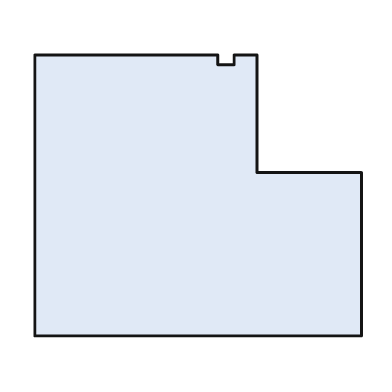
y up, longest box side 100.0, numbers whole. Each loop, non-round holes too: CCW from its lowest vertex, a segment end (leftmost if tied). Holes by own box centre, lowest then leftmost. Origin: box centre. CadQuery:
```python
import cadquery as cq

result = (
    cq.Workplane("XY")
    .moveTo(-50.0, -43.0)
    .lineTo(50.0, -43.0)
    .lineTo(50.0, 7.0)
    .lineTo(18.0, 7.0)
    .lineTo(18.0, 43.0)
    .lineTo(11.0, 43.0)
    .lineTo(11.0, 40.0)
    .lineTo(6.0, 40.0)
    .lineTo(6.0, 43.0)
    .lineTo(-50.0, 43.0)
    .close()
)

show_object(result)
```